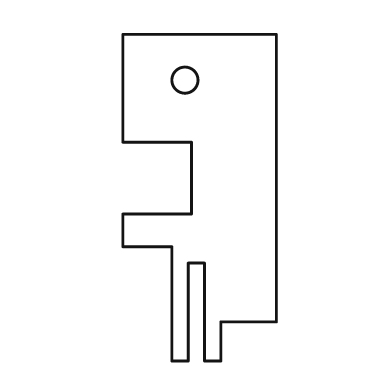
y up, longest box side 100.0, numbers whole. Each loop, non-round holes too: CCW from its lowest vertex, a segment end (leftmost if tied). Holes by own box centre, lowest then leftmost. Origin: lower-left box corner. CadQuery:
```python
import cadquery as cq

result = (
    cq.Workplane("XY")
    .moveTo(15.0, 0.0)
    .lineTo(20.0, 0.0)
    .lineTo(20.0, 30.0)
    .lineTo(25.0, 30.0)
    .lineTo(25.0, 0.0)
    .lineTo(30.0, 0.0)
    .lineTo(30.0, 12.0)
    .lineTo(47.0, 12.0)
    .lineTo(47.0, 100.0)
    .lineTo(0.0, 100.0)
    .lineTo(0.0, 67.0)
    .lineTo(21.0, 67.0)
    .lineTo(21.0, 45.0)
    .lineTo(0.0, 45.0)
    .lineTo(0.0, 35.0)
    .lineTo(15.0, 35.0)
    .close()
    .moveTo(19.0, 86.0)
    .circle(4.0)
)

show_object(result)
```